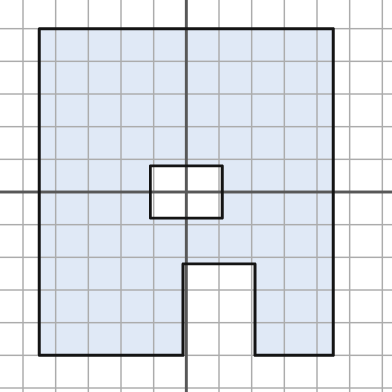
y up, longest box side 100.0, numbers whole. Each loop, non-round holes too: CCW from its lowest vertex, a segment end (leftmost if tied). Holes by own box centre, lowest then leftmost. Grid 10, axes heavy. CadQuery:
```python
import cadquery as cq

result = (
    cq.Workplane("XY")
    .moveTo(-45.0, -50.0)
    .lineTo(-1.0, -50.0)
    .lineTo(-1.0, -22.0)
    .lineTo(21.0, -22.0)
    .lineTo(21.0, -50.0)
    .lineTo(45.0, -50.0)
    .lineTo(45.0, 50.0)
    .lineTo(-45.0, 50.0)
    .close()
    .moveTo(-11.0, -8.0)
    .lineTo(11.0, -8.0)
    .lineTo(11.0, 8.0)
    .lineTo(-11.0, 8.0)
    .close()
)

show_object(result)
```